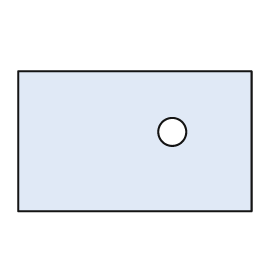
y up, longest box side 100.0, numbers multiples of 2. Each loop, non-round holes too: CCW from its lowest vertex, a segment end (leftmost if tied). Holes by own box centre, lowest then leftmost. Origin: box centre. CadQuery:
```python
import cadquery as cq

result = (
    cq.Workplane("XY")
    .moveTo(-50.0, -30.0)
    .lineTo(50.0, -30.0)
    .lineTo(50.0, 30.0)
    .lineTo(-50.0, 30.0)
    .close()
    .moveTo(16.0, 4.0)
    .circle(6.0)
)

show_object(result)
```